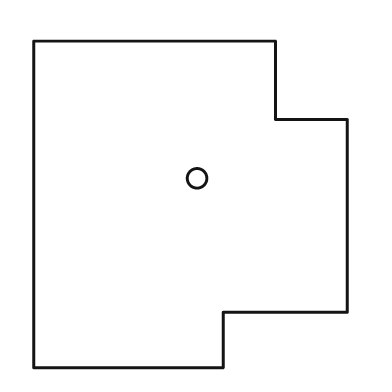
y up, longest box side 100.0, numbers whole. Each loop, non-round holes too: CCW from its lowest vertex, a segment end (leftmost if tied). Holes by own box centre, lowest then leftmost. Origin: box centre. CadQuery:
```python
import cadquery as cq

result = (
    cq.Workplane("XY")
    .moveTo(-48.0, -50.0)
    .lineTo(10.0, -50.0)
    .lineTo(10.0, -33.0)
    .lineTo(48.0, -33.0)
    .lineTo(48.0, 26.0)
    .lineTo(26.0, 26.0)
    .lineTo(26.0, 50.0)
    .lineTo(-48.0, 50.0)
    .close()
    .moveTo(2.0, 8.0)
    .circle(3.0)
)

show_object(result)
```